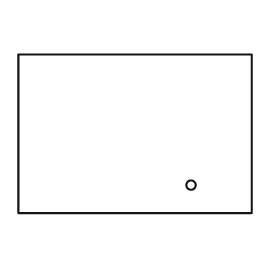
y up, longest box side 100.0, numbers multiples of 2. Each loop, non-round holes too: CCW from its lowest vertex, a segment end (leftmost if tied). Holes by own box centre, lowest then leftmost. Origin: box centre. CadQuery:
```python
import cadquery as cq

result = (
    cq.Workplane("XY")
    .moveTo(-50.0, -34.0)
    .lineTo(50.0, -34.0)
    .lineTo(50.0, 34.0)
    .lineTo(-50.0, 34.0)
    .close()
    .moveTo(24.0, -22.0)
    .circle(2.0)
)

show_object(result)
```